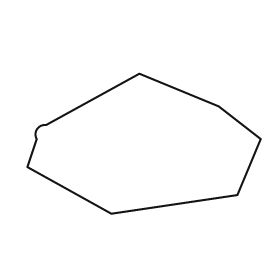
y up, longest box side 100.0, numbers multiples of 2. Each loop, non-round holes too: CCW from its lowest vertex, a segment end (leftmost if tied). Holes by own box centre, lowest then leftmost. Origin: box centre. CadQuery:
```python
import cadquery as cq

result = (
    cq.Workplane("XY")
    .moveTo(-14.0, -30.0)
    .lineTo(40.0, -22.0)
    .lineTo(50.0, 2.0)
    .lineTo(32.0, 16.0)
    .lineTo(-2.0, 30.0)
    .lineTo(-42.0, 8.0)
    .threePointArc((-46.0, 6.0), (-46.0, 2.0))
    .lineTo(-50.0, -10.0)
    .close()
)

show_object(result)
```